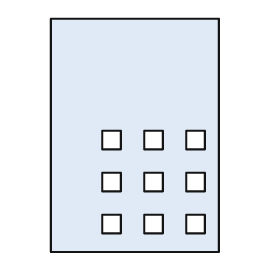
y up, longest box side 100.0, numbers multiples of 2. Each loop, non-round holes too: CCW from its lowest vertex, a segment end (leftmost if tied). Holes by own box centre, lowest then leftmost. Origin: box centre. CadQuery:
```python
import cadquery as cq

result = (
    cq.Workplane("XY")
    .moveTo(-36.0, -50.0)
    .lineTo(36.0, -50.0)
    .lineTo(36.0, 50.0)
    .lineTo(-36.0, 50.0)
    .close()
    .moveTo(-14.0, -42.0)
    .lineTo(-6.0, -42.0)
    .lineTo(-6.0, -34.0)
    .lineTo(-14.0, -34.0)
    .close()
    .moveTo(4.0, -42.0)
    .lineTo(12.0, -42.0)
    .lineTo(12.0, -34.0)
    .lineTo(4.0, -34.0)
    .close()
    .moveTo(22.0, -42.0)
    .lineTo(30.0, -42.0)
    .lineTo(30.0, -34.0)
    .lineTo(22.0, -34.0)
    .close()
    .moveTo(-14.0, -24.0)
    .lineTo(-6.0, -24.0)
    .lineTo(-6.0, -16.0)
    .lineTo(-14.0, -16.0)
    .close()
    .moveTo(4.0, -24.0)
    .lineTo(12.0, -24.0)
    .lineTo(12.0, -16.0)
    .lineTo(4.0, -16.0)
    .close()
    .moveTo(22.0, -24.0)
    .lineTo(30.0, -24.0)
    .lineTo(30.0, -16.0)
    .lineTo(22.0, -16.0)
    .close()
    .moveTo(-14.0, -6.0)
    .lineTo(-6.0, -6.0)
    .lineTo(-6.0, 2.0)
    .lineTo(-14.0, 2.0)
    .close()
    .moveTo(4.0, -6.0)
    .lineTo(12.0, -6.0)
    .lineTo(12.0, 2.0)
    .lineTo(4.0, 2.0)
    .close()
    .moveTo(22.0, -6.0)
    .lineTo(30.0, -6.0)
    .lineTo(30.0, 2.0)
    .lineTo(22.0, 2.0)
    .close()
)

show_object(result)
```